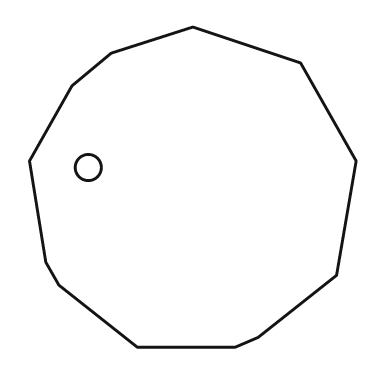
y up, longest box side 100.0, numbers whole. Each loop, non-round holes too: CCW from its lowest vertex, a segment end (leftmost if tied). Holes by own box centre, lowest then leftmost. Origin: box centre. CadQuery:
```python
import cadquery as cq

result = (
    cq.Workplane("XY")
    .moveTo(-17.0, -49.0)
    .lineTo(13.0, -49.0)
    .lineTo(20.0, -46.0)
    .lineTo(44.0, -27.0)
    .lineTo(50.0, 8.0)
    .lineTo(33.0, 38.0)
    .lineTo(0.0, 49.0)
    .lineTo(-25.0, 41.0)
    .lineTo(-37.0, 31.0)
    .lineTo(-50.0, 8.0)
    .lineTo(-45.0, -23.0)
    .lineTo(-41.0, -30.0)
    .close()
    .moveTo(-32.0, 6.0)
    .circle(4.0)
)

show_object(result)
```